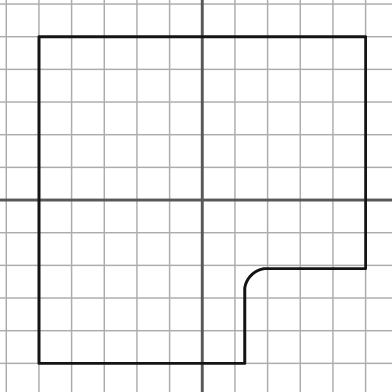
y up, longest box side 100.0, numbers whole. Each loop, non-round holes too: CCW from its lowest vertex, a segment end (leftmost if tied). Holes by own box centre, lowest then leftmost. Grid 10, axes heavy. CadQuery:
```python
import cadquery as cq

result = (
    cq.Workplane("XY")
    .moveTo(-50.0, -50.0)
    .lineTo(13.0, -50.0)
    .lineTo(13.0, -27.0)
    .threePointArc((15.0, -23.0), (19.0, -21.0))
    .lineTo(50.0, -21.0)
    .lineTo(50.0, 50.0)
    .lineTo(-50.0, 50.0)
    .close()
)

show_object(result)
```